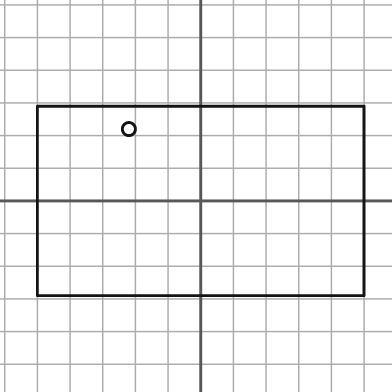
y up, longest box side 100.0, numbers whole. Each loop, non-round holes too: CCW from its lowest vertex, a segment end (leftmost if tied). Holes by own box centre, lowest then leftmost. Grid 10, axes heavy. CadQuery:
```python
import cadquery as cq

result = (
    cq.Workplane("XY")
    .moveTo(-50.0, -29.0)
    .lineTo(50.0, -29.0)
    .lineTo(50.0, 29.0)
    .lineTo(-50.0, 29.0)
    .close()
    .moveTo(-22.0, 22.0)
    .circle(2.0)
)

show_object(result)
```